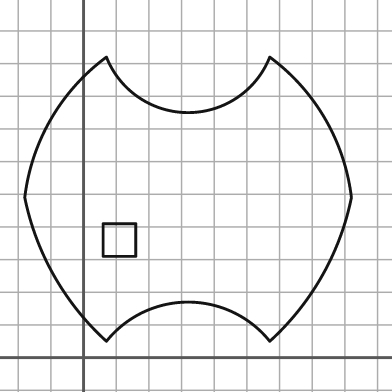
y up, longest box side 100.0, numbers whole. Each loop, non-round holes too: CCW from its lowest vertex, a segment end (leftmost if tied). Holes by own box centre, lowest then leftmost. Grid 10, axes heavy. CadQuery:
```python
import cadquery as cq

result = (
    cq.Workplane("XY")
    .moveTo(7.0, 5.0)
    .threePointArc((32.0, 17.0), (57.0, 5.0))
    .threePointArc((73.0, 25.0), (82.0, 49.0))
    .threePointArc((74.0, 73.0), (57.0, 92.0))
    .threePointArc((32.0, 75.0), (7.0, 92.0))
    .threePointArc((-10.0, 73.0), (-18.0, 49.0))
    .threePointArc((-9.0, 25.0), (7.0, 5.0))
    .close()
    .moveTo(6.0, 31.0)
    .lineTo(16.0, 31.0)
    .lineTo(16.0, 41.0)
    .lineTo(6.0, 41.0)
    .close()
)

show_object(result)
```